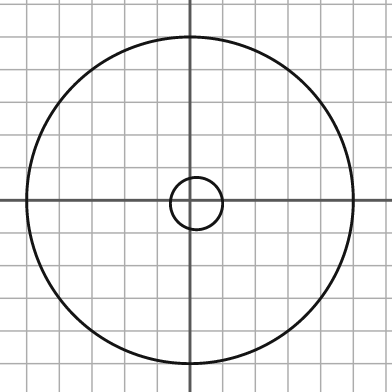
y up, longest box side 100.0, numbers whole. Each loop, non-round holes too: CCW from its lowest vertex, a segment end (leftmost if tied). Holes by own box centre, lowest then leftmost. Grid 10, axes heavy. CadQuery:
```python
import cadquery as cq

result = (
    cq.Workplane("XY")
    .moveTo(0.0, 0.0)
    .circle(50.0)
    .moveTo(2.0, -1.0)
    .circle(8.0)
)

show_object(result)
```